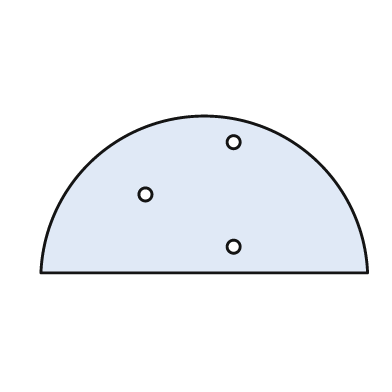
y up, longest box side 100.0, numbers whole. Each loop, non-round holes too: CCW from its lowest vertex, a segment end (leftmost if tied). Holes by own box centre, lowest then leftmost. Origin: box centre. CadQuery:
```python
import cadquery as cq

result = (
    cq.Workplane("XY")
    .moveTo(-50.0, -24.0)
    .lineTo(50.0, -24.0)
    .threePointArc((0.0, 24.0), (-50.0, -24.0))
    .close()
    .moveTo(9.0, -16.0)
    .circle(2.0)
    .moveTo(-18.0, 0.0)
    .circle(2.0)
    .moveTo(9.0, 16.0)
    .circle(2.0)
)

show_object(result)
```